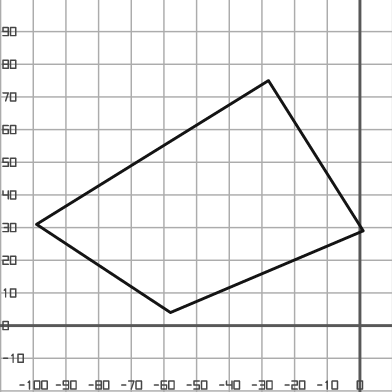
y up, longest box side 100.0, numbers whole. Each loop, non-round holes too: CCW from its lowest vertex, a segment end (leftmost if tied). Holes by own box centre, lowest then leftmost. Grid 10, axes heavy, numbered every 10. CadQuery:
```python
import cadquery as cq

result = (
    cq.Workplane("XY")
    .moveTo(-58.0, 4.0)
    .lineTo(1.0, 29.0)
    .lineTo(-28.0, 75.0)
    .lineTo(-99.0, 31.0)
    .close()
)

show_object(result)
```